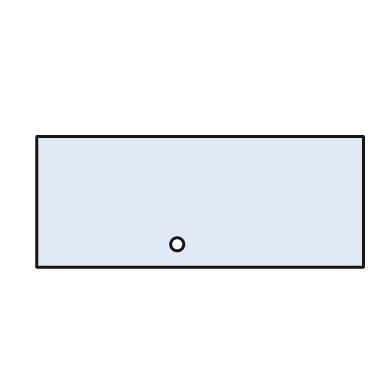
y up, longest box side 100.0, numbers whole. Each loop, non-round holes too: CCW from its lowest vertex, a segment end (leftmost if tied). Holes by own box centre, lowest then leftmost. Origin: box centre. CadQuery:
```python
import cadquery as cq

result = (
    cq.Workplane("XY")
    .moveTo(-50.0, -20.0)
    .lineTo(50.0, -20.0)
    .lineTo(50.0, 20.0)
    .lineTo(-50.0, 20.0)
    .close()
    .moveTo(-7.0, -13.0)
    .circle(2.0)
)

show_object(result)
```